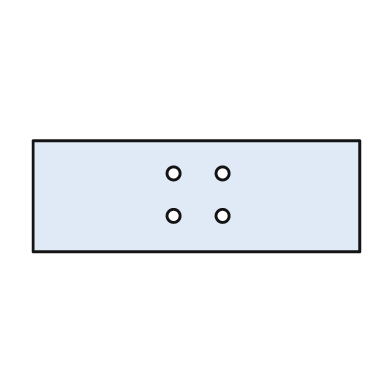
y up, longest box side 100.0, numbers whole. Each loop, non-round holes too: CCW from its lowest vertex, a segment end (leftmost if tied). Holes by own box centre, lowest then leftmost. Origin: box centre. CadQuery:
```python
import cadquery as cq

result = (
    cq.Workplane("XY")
    .moveTo(-50.0, -17.0)
    .lineTo(50.0, -17.0)
    .lineTo(50.0, 17.0)
    .lineTo(-50.0, 17.0)
    .close()
    .moveTo(-7.0, -6.0)
    .circle(2.0)
    .moveTo(8.0, -6.0)
    .circle(2.0)
    .moveTo(-7.0, 7.0)
    .circle(2.0)
    .moveTo(8.0, 7.0)
    .circle(2.0)
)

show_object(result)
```